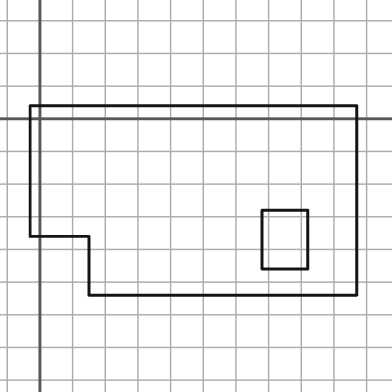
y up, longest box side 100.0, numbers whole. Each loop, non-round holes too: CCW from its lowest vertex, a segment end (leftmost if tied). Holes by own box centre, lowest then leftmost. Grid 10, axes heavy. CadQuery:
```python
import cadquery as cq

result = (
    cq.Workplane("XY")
    .moveTo(15.0, -54.0)
    .lineTo(97.0, -54.0)
    .lineTo(97.0, 4.0)
    .lineTo(-3.0, 4.0)
    .lineTo(-3.0, -36.0)
    .lineTo(15.0, -36.0)
    .close()
    .moveTo(68.0, -46.0)
    .lineTo(82.0, -46.0)
    .lineTo(82.0, -28.0)
    .lineTo(68.0, -28.0)
    .close()
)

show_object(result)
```